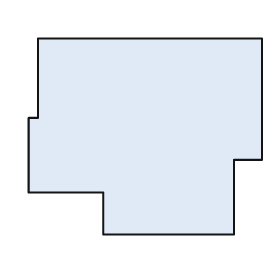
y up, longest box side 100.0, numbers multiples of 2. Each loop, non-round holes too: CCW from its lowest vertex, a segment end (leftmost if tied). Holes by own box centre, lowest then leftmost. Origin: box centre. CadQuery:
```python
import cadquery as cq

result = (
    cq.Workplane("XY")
    .moveTo(-18.0, -42.0)
    .lineTo(38.0, -42.0)
    .lineTo(38.0, -10.0)
    .lineTo(50.0, -10.0)
    .lineTo(50.0, 42.0)
    .lineTo(-46.0, 42.0)
    .lineTo(-46.0, 8.0)
    .lineTo(-50.0, 8.0)
    .lineTo(-50.0, -24.0)
    .lineTo(-18.0, -24.0)
    .close()
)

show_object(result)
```